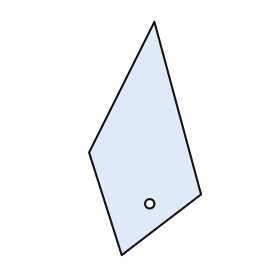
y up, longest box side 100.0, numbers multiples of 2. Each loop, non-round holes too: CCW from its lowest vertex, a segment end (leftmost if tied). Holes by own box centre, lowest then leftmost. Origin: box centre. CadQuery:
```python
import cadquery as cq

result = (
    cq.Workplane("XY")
    .moveTo(-10.0, -50.0)
    .lineTo(24.0, -24.0)
    .lineTo(4.0, 50.0)
    .lineTo(-24.0, -6.0)
    .close()
    .moveTo(2.0, -28.0)
    .circle(2.0)
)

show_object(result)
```